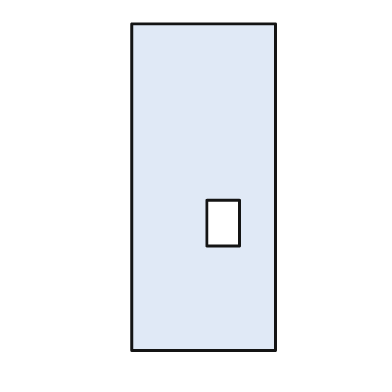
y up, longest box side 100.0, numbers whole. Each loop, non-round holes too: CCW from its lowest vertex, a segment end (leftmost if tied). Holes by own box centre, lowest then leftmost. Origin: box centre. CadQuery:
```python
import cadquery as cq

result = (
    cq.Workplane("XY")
    .moveTo(-22.0, -50.0)
    .lineTo(22.0, -50.0)
    .lineTo(22.0, 50.0)
    .lineTo(-22.0, 50.0)
    .close()
    .moveTo(1.0, -18.0)
    .lineTo(11.0, -18.0)
    .lineTo(11.0, -4.0)
    .lineTo(1.0, -4.0)
    .close()
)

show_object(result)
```